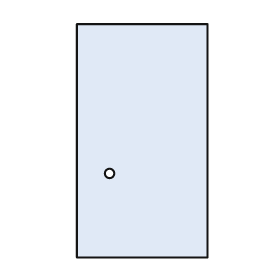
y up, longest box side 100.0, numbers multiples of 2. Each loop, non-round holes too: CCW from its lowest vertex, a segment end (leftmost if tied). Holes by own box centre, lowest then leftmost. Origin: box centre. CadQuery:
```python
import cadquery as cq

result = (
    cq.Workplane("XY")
    .moveTo(-28.0, -50.0)
    .lineTo(28.0, -50.0)
    .lineTo(28.0, 50.0)
    .lineTo(-28.0, 50.0)
    .close()
    .moveTo(-14.0, -14.0)
    .circle(2.0)
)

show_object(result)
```